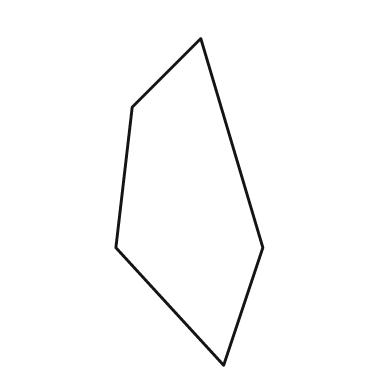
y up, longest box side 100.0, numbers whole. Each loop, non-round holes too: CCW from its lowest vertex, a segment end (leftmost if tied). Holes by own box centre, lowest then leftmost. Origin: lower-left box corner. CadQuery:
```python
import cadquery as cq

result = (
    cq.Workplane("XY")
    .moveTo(33.0, 0.0)
    .lineTo(45.0, 36.0)
    .lineTo(26.0, 100.0)
    .lineTo(5.0, 79.0)
    .lineTo(0.0, 36.0)
    .close()
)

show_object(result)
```